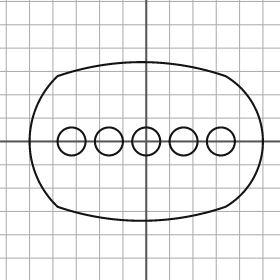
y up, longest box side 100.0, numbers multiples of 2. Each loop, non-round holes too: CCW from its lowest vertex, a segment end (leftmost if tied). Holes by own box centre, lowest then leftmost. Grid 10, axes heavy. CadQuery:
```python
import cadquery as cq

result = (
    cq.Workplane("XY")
    .moveTo(-38.0, -28.0)
    .threePointArc((-2.0, -34.0), (34.0, -28.0))
    .threePointArc((50.0, 0.0), (34.0, 28.0))
    .threePointArc((-2.0, 34.0), (-38.0, 28.0))
    .threePointArc((-50.0, 0.0), (-38.0, -28.0))
    .close()
    .moveTo(-32.0, 0.0)
    .circle(6.0)
    .moveTo(-16.0, 0.0)
    .circle(6.0)
    .moveTo(0.0, 0.0)
    .circle(6.0)
    .moveTo(16.0, 0.0)
    .circle(6.0)
    .moveTo(32.0, 0.0)
    .circle(6.0)
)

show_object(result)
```